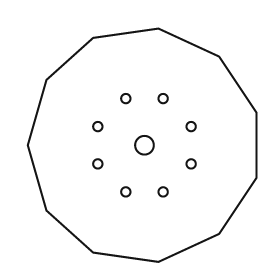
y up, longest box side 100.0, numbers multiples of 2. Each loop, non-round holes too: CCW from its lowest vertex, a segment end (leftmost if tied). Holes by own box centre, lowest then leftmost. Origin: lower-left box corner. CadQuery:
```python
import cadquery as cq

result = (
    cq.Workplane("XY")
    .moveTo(56.0, 0.0)
    .lineTo(82.0, 12.0)
    .lineTo(98.0, 36.0)
    .lineTo(98.0, 64.0)
    .lineTo(82.0, 88.0)
    .lineTo(56.0, 100.0)
    .lineTo(28.0, 96.0)
    .lineTo(8.0, 78.0)
    .lineTo(0.0, 50.0)
    .lineTo(8.0, 22.0)
    .lineTo(28.0, 4.0)
    .close()
    .moveTo(42.0, 30.0)
    .circle(2.0)
    .moveTo(58.0, 30.0)
    .circle(2.0)
    .moveTo(30.0, 42.0)
    .circle(2.0)
    .moveTo(70.0, 42.0)
    .circle(2.0)
    .moveTo(50.0, 50.0)
    .circle(4.0)
    .moveTo(30.0, 58.0)
    .circle(2.0)
    .moveTo(70.0, 58.0)
    .circle(2.0)
    .moveTo(42.0, 70.0)
    .circle(2.0)
    .moveTo(58.0, 70.0)
    .circle(2.0)
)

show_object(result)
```